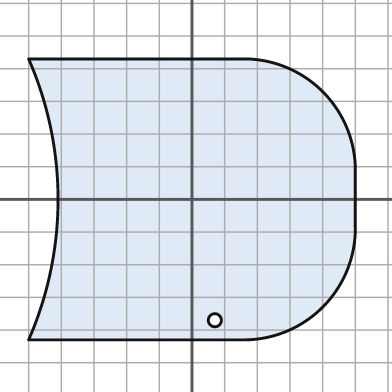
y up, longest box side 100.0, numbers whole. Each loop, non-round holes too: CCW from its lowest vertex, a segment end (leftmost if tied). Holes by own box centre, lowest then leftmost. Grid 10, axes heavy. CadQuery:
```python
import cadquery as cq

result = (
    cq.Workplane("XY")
    .moveTo(-50.0, -43.0)
    .lineTo(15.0, -43.0)
    .threePointArc((40.0, -33.0), (50.0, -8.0))
    .lineTo(50.0, 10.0)
    .threePointArc((40.0, 33.0), (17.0, 43.0))
    .lineTo(-50.0, 43.0)
    .threePointArc((-41.0, 0.0), (-50.0, -43.0))
    .close()
    .moveTo(7.0, -37.0)
    .circle(2.0)
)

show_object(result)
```